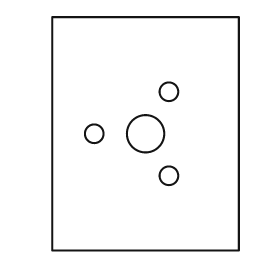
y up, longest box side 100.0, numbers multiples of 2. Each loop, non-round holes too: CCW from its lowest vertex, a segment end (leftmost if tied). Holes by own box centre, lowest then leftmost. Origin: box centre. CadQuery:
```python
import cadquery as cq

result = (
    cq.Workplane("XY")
    .moveTo(-40.0, -50.0)
    .lineTo(40.0, -50.0)
    .lineTo(40.0, 50.0)
    .lineTo(-40.0, 50.0)
    .close()
    .moveTo(10.0, -18.0)
    .circle(4.0)
    .moveTo(-22.0, 0.0)
    .circle(4.0)
    .moveTo(0.0, 0.0)
    .circle(8.0)
    .moveTo(10.0, 18.0)
    .circle(4.0)
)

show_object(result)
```